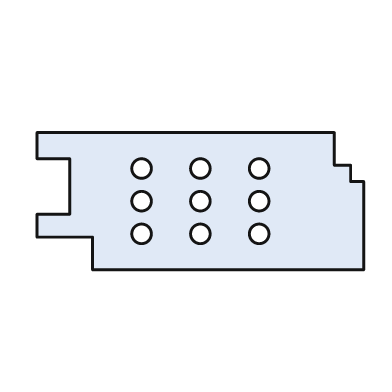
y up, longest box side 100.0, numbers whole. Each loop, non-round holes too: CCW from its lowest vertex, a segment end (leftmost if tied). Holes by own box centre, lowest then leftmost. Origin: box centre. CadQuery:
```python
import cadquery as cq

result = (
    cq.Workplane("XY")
    .moveTo(-33.0, -21.0)
    .lineTo(50.0, -21.0)
    .lineTo(50.0, 6.0)
    .lineTo(46.0, 6.0)
    .lineTo(46.0, 11.0)
    .lineTo(41.0, 11.0)
    .lineTo(41.0, 21.0)
    .lineTo(-50.0, 21.0)
    .lineTo(-50.0, 13.0)
    .lineTo(-40.0, 13.0)
    .lineTo(-40.0, -4.0)
    .lineTo(-50.0, -4.0)
    .lineTo(-50.0, -11.0)
    .lineTo(-33.0, -11.0)
    .close()
    .moveTo(-18.0, -10.0)
    .circle(3.0)
    .moveTo(0.0, -10.0)
    .circle(3.0)
    .moveTo(18.0, -10.0)
    .circle(3.0)
    .moveTo(-18.0, 0.0)
    .circle(3.0)
    .moveTo(0.0, 0.0)
    .circle(3.0)
    .moveTo(18.0, 0.0)
    .circle(3.0)
    .moveTo(-18.0, 10.0)
    .circle(3.0)
    .moveTo(0.0, 10.0)
    .circle(3.0)
    .moveTo(18.0, 10.0)
    .circle(3.0)
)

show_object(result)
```